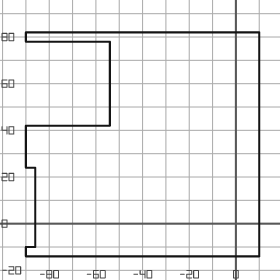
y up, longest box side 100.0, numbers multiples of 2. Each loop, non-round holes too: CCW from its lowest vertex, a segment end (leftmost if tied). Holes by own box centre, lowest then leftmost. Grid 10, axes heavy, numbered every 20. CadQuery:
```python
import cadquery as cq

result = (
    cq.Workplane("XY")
    .moveTo(-90.0, -14.0)
    .lineTo(10.0, -14.0)
    .lineTo(10.0, 82.0)
    .lineTo(-90.0, 82.0)
    .lineTo(-90.0, 78.0)
    .lineTo(-54.0, 78.0)
    .lineTo(-54.0, 42.0)
    .lineTo(-90.0, 42.0)
    .lineTo(-90.0, 24.0)
    .lineTo(-86.0, 24.0)
    .lineTo(-86.0, -10.0)
    .lineTo(-90.0, -10.0)
    .close()
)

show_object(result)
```